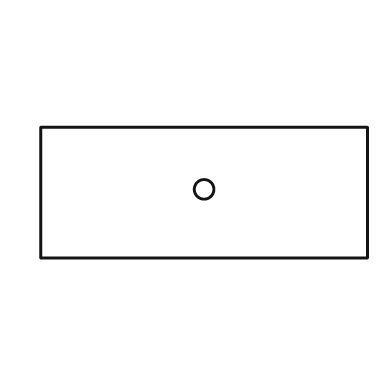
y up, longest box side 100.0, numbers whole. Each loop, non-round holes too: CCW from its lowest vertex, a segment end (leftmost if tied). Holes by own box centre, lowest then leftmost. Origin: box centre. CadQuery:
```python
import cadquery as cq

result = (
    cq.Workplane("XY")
    .moveTo(-50.0, -20.0)
    .lineTo(50.0, -20.0)
    .lineTo(50.0, 20.0)
    .lineTo(-50.0, 20.0)
    .close()
    .moveTo(0.0, 1.0)
    .circle(3.0)
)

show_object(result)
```